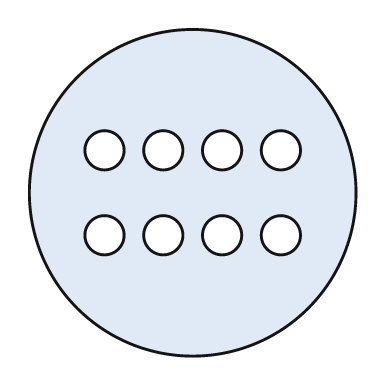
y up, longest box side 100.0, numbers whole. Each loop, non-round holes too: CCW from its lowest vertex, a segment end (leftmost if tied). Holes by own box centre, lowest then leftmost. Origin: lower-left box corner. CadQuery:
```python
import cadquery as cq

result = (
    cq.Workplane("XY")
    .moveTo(50.0, 50.0)
    .circle(50.0)
    .moveTo(23.0, 37.0)
    .circle(6.0)
    .moveTo(41.0, 37.0)
    .circle(6.0)
    .moveTo(59.0, 37.0)
    .circle(6.0)
    .moveTo(77.0, 37.0)
    .circle(6.0)
    .moveTo(23.0, 63.0)
    .circle(6.0)
    .moveTo(41.0, 63.0)
    .circle(6.0)
    .moveTo(59.0, 63.0)
    .circle(6.0)
    .moveTo(77.0, 63.0)
    .circle(6.0)
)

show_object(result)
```